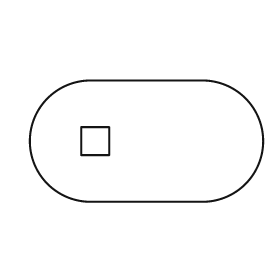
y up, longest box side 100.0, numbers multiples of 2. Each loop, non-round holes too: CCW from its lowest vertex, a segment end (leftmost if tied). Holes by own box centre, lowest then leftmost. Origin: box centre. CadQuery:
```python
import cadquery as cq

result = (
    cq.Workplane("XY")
    .moveTo(-24.0, -26.0)
    .lineTo(24.0, -26.0)
    .threePointArc((50.0, 0.0), (24.0, 26.0))
    .lineTo(-24.0, 26.0)
    .threePointArc((-50.0, 0.0), (-24.0, -26.0))
    .close()
    .moveTo(-28.0, -6.0)
    .lineTo(-16.0, -6.0)
    .lineTo(-16.0, 6.0)
    .lineTo(-28.0, 6.0)
    .close()
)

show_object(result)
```